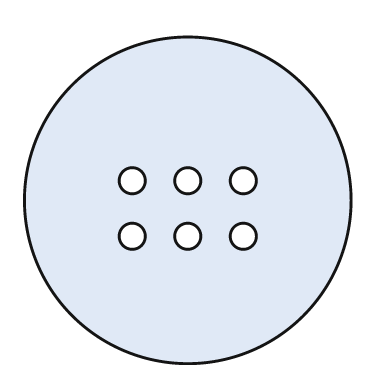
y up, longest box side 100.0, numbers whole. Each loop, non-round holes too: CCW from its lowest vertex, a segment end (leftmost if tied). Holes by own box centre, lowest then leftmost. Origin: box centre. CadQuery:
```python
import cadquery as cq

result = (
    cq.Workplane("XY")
    .moveTo(0.0, 0.0)
    .circle(50.0)
    .moveTo(-17.0, -11.0)
    .circle(4.0)
    .moveTo(0.0, -11.0)
    .circle(4.0)
    .moveTo(17.0, -11.0)
    .circle(4.0)
    .moveTo(-17.0, 6.0)
    .circle(4.0)
    .moveTo(0.0, 6.0)
    .circle(4.0)
    .moveTo(17.0, 6.0)
    .circle(4.0)
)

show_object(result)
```